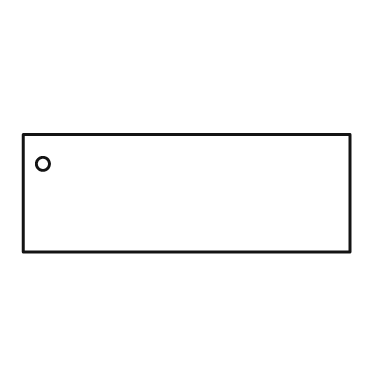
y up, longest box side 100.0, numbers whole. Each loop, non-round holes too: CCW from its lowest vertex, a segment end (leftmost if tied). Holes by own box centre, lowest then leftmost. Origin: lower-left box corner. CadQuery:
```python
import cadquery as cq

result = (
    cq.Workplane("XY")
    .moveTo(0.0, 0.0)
    .lineTo(100.0, 0.0)
    .lineTo(100.0, 36.0)
    .lineTo(0.0, 36.0)
    .close()
    .moveTo(6.0, 27.0)
    .circle(2.0)
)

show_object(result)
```